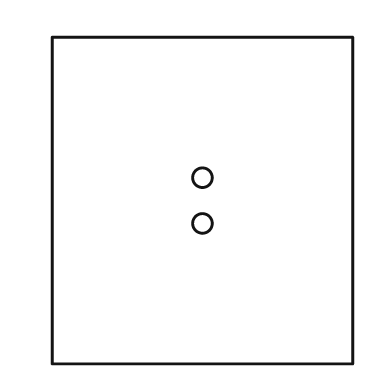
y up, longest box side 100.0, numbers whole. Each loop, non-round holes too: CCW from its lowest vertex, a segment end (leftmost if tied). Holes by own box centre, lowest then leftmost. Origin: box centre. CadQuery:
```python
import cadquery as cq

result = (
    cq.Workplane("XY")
    .moveTo(-46.0, -50.0)
    .lineTo(46.0, -50.0)
    .lineTo(46.0, 50.0)
    .lineTo(-46.0, 50.0)
    .close()
    .moveTo(0.0, -7.0)
    .circle(3.0)
    .moveTo(0.0, 7.0)
    .circle(3.0)
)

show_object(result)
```